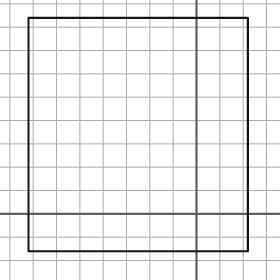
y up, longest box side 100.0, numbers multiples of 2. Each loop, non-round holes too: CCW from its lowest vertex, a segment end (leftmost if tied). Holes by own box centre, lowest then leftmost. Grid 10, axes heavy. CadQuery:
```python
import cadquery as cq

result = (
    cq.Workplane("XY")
    .moveTo(-72.0, -16.0)
    .lineTo(22.0, -16.0)
    .lineTo(22.0, 84.0)
    .lineTo(-72.0, 84.0)
    .close()
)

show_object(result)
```